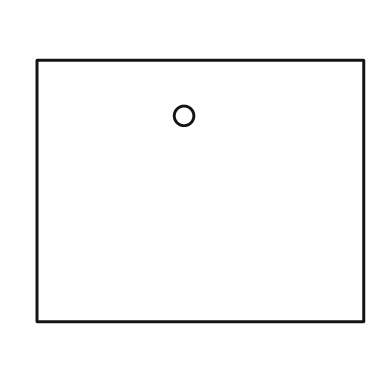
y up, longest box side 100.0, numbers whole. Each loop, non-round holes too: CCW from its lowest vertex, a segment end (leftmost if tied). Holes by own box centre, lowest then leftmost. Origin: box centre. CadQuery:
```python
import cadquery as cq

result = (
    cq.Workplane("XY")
    .moveTo(-50.0, -40.0)
    .lineTo(50.0, -40.0)
    .lineTo(50.0, 40.0)
    .lineTo(-50.0, 40.0)
    .close()
    .moveTo(-5.0, 23.0)
    .circle(3.0)
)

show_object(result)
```